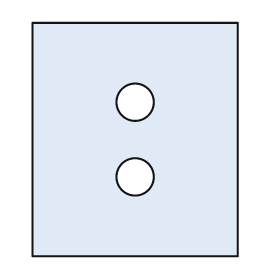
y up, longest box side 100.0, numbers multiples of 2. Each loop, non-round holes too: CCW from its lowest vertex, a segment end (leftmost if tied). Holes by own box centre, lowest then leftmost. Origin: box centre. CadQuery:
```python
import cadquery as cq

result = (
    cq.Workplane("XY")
    .moveTo(-44.0, -50.0)
    .lineTo(44.0, -50.0)
    .lineTo(44.0, 50.0)
    .lineTo(-44.0, 50.0)
    .close()
    .moveTo(0.0, -16.0)
    .circle(8.0)
    .moveTo(0.0, 16.0)
    .circle(8.0)
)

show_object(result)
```